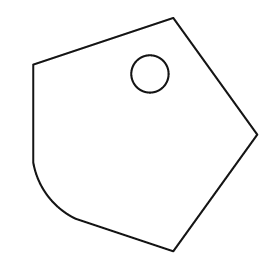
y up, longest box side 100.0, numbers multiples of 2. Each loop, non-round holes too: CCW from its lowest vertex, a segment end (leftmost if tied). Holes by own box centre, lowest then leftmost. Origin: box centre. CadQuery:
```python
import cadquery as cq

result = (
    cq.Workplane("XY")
    .moveTo(12.0, -50.0)
    .lineTo(48.0, 0.0)
    .lineTo(12.0, 50.0)
    .lineTo(-48.0, 30.0)
    .lineTo(-48.0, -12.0)
    .threePointArc((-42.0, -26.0), (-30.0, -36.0))
    .close()
    .moveTo(2.0, 26.0)
    .circle(8.0)
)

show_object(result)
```